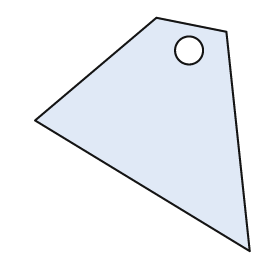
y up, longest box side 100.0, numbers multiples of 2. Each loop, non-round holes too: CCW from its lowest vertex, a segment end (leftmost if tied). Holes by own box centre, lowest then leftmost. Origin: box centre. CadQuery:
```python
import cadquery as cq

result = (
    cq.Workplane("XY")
    .moveTo(46.0, -50.0)
    .lineTo(36.0, 44.0)
    .lineTo(6.0, 50.0)
    .lineTo(-46.0, 6.0)
    .close()
    .moveTo(20.0, 36.0)
    .circle(6.0)
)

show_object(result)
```